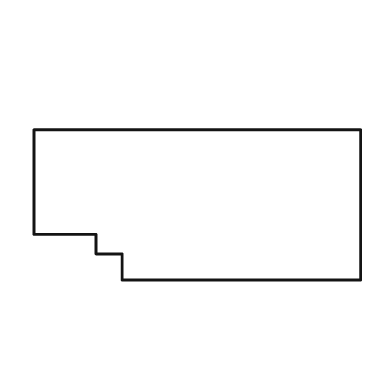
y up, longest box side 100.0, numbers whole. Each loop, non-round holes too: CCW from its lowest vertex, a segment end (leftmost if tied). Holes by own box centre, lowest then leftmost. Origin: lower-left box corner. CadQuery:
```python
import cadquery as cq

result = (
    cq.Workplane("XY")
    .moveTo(27.0, 0.0)
    .lineTo(100.0, 0.0)
    .lineTo(100.0, 46.0)
    .lineTo(0.0, 46.0)
    .lineTo(0.0, 14.0)
    .lineTo(19.0, 14.0)
    .lineTo(19.0, 8.0)
    .lineTo(27.0, 8.0)
    .close()
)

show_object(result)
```